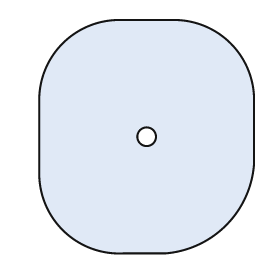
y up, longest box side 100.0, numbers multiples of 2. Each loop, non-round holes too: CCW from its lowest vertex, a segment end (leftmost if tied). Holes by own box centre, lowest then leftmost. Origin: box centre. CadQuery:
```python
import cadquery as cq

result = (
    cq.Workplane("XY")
    .moveTo(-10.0, -50.0)
    .lineTo(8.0, -50.0)
    .threePointArc((34.0, -38.0), (46.0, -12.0))
    .lineTo(46.0, 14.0)
    .threePointArc((36.0, 40.0), (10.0, 50.0))
    .lineTo(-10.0, 50.0)
    .threePointArc((-36.0, 40.0), (-46.0, 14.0))
    .lineTo(-46.0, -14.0)
    .threePointArc((-36.0, -40.0), (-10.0, -50.0))
    .close()
    .moveTo(0.0, 0.0)
    .circle(4.0)
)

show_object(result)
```